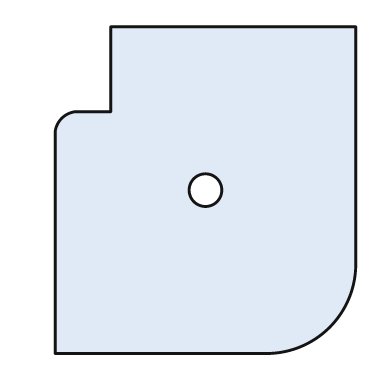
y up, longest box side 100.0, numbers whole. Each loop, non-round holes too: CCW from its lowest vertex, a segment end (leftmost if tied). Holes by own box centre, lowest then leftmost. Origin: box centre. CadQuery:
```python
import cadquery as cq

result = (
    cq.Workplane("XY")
    .moveTo(-46.0, -50.0)
    .lineTo(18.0, -50.0)
    .threePointArc((38.0, -42.0), (46.0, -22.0))
    .lineTo(46.0, 50.0)
    .lineTo(-29.0, 50.0)
    .lineTo(-29.0, 24.0)
    .lineTo(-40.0, 24.0)
    .threePointArc((-44.0, 22.0), (-46.0, 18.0))
    .close()
    .moveTo(0.0, 0.0)
    .circle(5.0)
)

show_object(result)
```